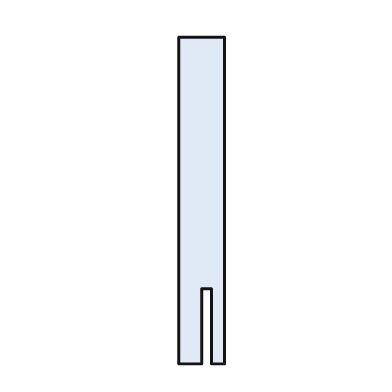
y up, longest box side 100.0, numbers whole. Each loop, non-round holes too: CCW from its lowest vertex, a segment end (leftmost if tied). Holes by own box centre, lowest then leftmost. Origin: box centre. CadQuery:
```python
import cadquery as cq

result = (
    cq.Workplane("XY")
    .moveTo(-7.0, -50.0)
    .lineTo(0.0, -50.0)
    .lineTo(0.0, -27.0)
    .lineTo(3.0, -27.0)
    .lineTo(3.0, -50.0)
    .lineTo(7.0, -50.0)
    .lineTo(7.0, 50.0)
    .lineTo(-7.0, 50.0)
    .close()
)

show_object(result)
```